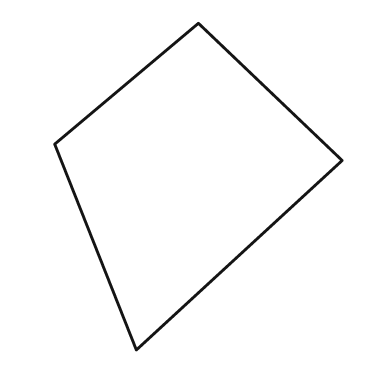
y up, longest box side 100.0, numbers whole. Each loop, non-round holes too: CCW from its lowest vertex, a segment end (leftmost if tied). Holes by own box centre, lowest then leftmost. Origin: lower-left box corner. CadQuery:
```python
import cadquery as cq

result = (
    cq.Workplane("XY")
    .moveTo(25.0, 0.0)
    .lineTo(88.0, 58.0)
    .lineTo(44.0, 100.0)
    .lineTo(0.0, 63.0)
    .close()
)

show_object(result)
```